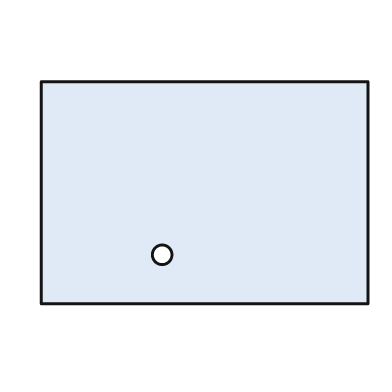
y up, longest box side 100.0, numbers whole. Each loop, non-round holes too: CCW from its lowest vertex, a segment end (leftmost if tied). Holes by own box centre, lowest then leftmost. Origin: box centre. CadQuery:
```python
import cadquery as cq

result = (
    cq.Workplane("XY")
    .moveTo(-50.0, -34.0)
    .lineTo(50.0, -34.0)
    .lineTo(50.0, 34.0)
    .lineTo(-50.0, 34.0)
    .close()
    .moveTo(-13.0, -19.0)
    .circle(3.0)
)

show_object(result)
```